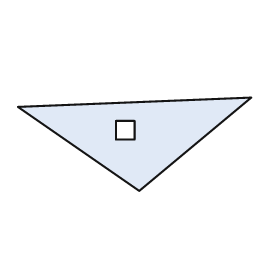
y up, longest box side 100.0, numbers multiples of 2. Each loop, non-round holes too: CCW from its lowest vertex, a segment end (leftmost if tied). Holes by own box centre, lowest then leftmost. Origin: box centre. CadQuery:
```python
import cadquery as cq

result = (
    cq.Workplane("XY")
    .moveTo(2.0, -20.0)
    .lineTo(50.0, 20.0)
    .lineTo(-50.0, 16.0)
    .close()
    .moveTo(-8.0, 2.0)
    .lineTo(0.0, 2.0)
    .lineTo(0.0, 10.0)
    .lineTo(-8.0, 10.0)
    .close()
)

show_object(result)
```